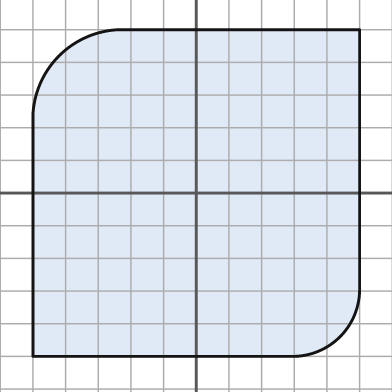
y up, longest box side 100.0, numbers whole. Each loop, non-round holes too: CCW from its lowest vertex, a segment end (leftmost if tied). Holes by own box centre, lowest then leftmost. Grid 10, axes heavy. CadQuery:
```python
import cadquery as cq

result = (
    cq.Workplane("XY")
    .moveTo(-50.0, -50.0)
    .lineTo(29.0, -50.0)
    .threePointArc((44.0, -44.0), (50.0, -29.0))
    .lineTo(50.0, 50.0)
    .lineTo(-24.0, 50.0)
    .threePointArc((-42.0, 42.0), (-50.0, 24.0))
    .close()
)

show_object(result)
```